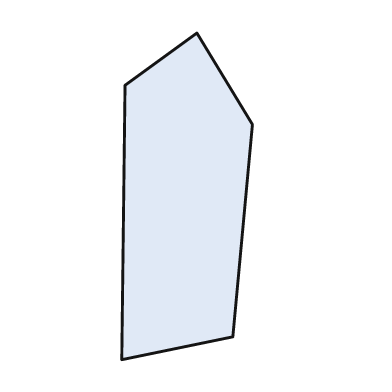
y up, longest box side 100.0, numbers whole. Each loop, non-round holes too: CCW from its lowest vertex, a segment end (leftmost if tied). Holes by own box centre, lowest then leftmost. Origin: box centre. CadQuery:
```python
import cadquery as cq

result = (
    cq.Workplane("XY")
    .moveTo(-20.0, -50.0)
    .lineTo(14.0, -43.0)
    .lineTo(20.0, 22.0)
    .lineTo(3.0, 50.0)
    .lineTo(-19.0, 34.0)
    .close()
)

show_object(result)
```